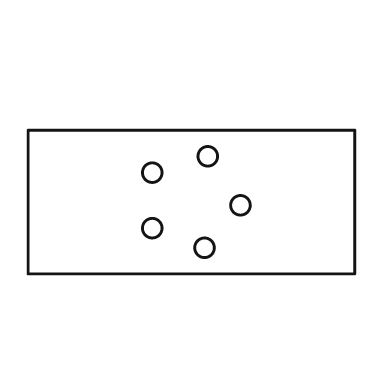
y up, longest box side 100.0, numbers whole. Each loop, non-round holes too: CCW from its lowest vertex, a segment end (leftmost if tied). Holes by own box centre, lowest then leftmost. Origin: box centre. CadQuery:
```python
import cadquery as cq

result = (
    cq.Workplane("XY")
    .moveTo(-50.0, -22.0)
    .lineTo(50.0, -22.0)
    .lineTo(50.0, 22.0)
    .lineTo(-50.0, 22.0)
    .close()
    .moveTo(4.0, -14.0)
    .circle(3.0)
    .moveTo(-12.0, -8.0)
    .circle(3.0)
    .moveTo(15.0, -1.0)
    .circle(3.0)
    .moveTo(-12.0, 9.0)
    .circle(3.0)
    .moveTo(5.0, 14.0)
    .circle(3.0)
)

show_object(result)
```